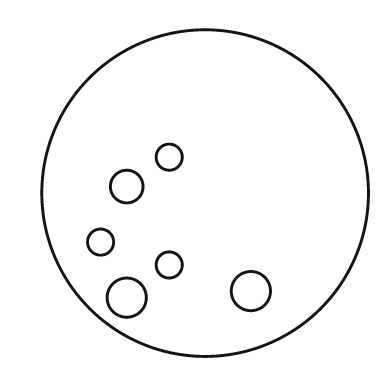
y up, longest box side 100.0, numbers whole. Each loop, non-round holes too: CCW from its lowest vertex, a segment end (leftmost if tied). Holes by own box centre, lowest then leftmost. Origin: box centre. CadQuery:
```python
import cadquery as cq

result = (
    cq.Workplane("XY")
    .moveTo(0.0, 0.0)
    .circle(50.0)
    .moveTo(-24.0, -32.0)
    .circle(6.0)
    .moveTo(14.0, -30.0)
    .circle(6.0)
    .moveTo(-11.0, -22.0)
    .circle(4.0)
    .moveTo(-32.0, -15.0)
    .circle(4.0)
    .moveTo(-24.0, 2.0)
    .circle(5.0)
    .moveTo(-11.0, 11.0)
    .circle(4.0)
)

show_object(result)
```